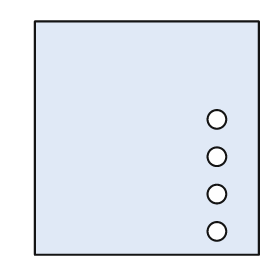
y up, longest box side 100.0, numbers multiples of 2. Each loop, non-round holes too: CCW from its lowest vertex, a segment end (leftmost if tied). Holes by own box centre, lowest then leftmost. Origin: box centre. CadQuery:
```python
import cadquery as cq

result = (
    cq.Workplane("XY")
    .moveTo(-48.0, -50.0)
    .lineTo(48.0, -50.0)
    .lineTo(48.0, 50.0)
    .lineTo(-48.0, 50.0)
    .close()
    .moveTo(30.0, -40.0)
    .circle(4.0)
    .moveTo(30.0, -24.0)
    .circle(4.0)
    .moveTo(30.0, -8.0)
    .circle(4.0)
    .moveTo(30.0, 8.0)
    .circle(4.0)
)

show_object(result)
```